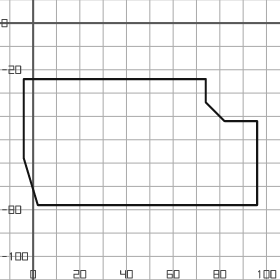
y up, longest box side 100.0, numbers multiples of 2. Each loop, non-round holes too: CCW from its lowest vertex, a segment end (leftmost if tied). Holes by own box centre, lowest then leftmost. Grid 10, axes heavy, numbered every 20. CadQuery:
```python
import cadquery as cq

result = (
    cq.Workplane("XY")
    .moveTo(2.0, -78.0)
    .lineTo(96.0, -78.0)
    .lineTo(96.0, -42.0)
    .lineTo(82.0, -42.0)
    .lineTo(74.0, -34.0)
    .lineTo(74.0, -24.0)
    .lineTo(-4.0, -24.0)
    .lineTo(-4.0, -58.0)
    .close()
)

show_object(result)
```